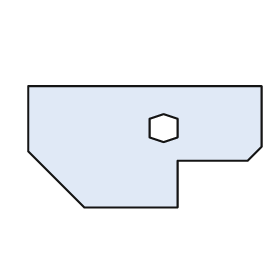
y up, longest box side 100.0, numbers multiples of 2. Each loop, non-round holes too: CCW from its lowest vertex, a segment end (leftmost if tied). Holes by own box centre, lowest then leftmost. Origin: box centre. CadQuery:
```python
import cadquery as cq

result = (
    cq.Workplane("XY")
    .moveTo(-26.0, -26.0)
    .lineTo(14.0, -26.0)
    .lineTo(14.0, -6.0)
    .lineTo(44.0, -6.0)
    .lineTo(50.0, 0.0)
    .lineTo(50.0, 26.0)
    .lineTo(-50.0, 26.0)
    .lineTo(-50.0, -2.0)
    .close()
    .moveTo(8.0, 2.0)
    .lineTo(14.0, 4.0)
    .lineTo(14.0, 12.0)
    .lineTo(8.0, 14.0)
    .lineTo(2.0, 12.0)
    .lineTo(2.0, 4.0)
    .close()
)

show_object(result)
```